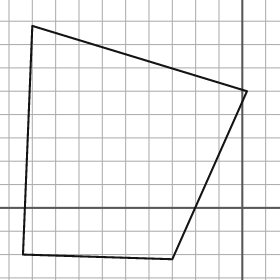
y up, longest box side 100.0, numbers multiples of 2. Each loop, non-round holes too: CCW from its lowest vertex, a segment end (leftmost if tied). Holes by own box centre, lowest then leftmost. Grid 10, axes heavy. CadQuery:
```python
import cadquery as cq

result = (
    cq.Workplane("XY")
    .moveTo(-30.0, -22.0)
    .lineTo(2.0, 50.0)
    .lineTo(-90.0, 78.0)
    .lineTo(-94.0, -20.0)
    .close()
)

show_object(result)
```